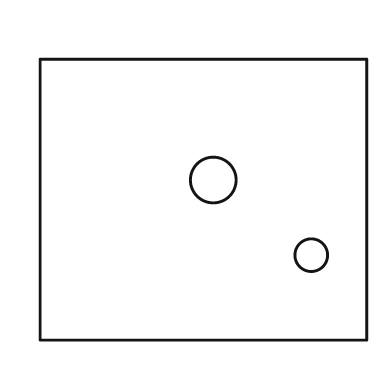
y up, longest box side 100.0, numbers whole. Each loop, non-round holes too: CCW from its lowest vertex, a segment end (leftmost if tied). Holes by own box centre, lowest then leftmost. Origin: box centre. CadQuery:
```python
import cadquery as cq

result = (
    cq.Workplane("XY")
    .moveTo(-50.0, -43.0)
    .lineTo(50.0, -43.0)
    .lineTo(50.0, 43.0)
    .lineTo(-50.0, 43.0)
    .close()
    .moveTo(33.0, -17.0)
    .circle(5.0)
    .moveTo(3.0, 6.0)
    .circle(7.0)
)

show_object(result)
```